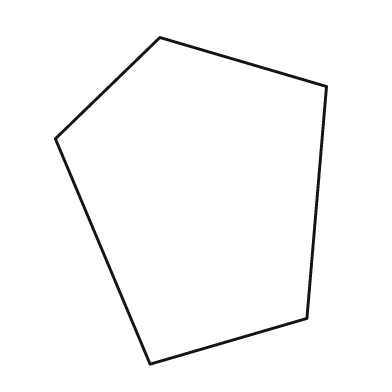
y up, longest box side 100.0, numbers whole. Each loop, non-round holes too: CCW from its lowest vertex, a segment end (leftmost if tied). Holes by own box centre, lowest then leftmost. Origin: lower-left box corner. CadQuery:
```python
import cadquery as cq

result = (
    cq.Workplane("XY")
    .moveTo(29.0, 0.0)
    .lineTo(77.0, 14.0)
    .lineTo(83.0, 85.0)
    .lineTo(32.0, 100.0)
    .lineTo(0.0, 69.0)
    .close()
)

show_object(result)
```